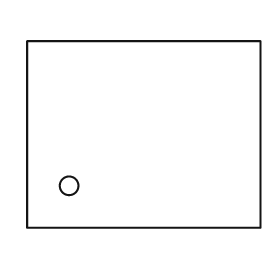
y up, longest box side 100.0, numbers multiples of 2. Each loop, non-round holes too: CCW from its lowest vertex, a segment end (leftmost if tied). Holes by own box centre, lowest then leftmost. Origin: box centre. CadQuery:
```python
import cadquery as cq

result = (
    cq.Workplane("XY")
    .moveTo(-50.0, -40.0)
    .lineTo(50.0, -40.0)
    .lineTo(50.0, 40.0)
    .lineTo(-50.0, 40.0)
    .close()
    .moveTo(-32.0, -22.0)
    .circle(4.0)
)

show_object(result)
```